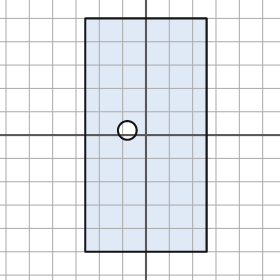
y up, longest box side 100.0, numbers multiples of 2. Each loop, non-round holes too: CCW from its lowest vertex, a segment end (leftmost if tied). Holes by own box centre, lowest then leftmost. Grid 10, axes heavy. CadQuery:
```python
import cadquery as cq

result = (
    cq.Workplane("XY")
    .moveTo(-26.0, -50.0)
    .lineTo(26.0, -50.0)
    .lineTo(26.0, 50.0)
    .lineTo(-26.0, 50.0)
    .close()
    .moveTo(-8.0, 2.0)
    .circle(4.0)
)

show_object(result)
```